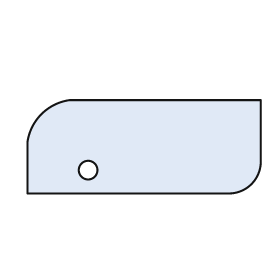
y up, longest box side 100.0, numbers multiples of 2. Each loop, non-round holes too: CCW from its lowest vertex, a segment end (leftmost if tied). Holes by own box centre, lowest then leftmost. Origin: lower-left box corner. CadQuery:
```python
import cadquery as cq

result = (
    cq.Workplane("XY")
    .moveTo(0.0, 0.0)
    .lineTo(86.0, 0.0)
    .threePointArc((96.0, 4.0), (100.0, 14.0))
    .lineTo(100.0, 40.0)
    .lineTo(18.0, 40.0)
    .threePointArc((6.0, 34.0), (0.0, 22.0))
    .close()
    .moveTo(26.0, 10.0)
    .circle(4.0)
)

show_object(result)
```